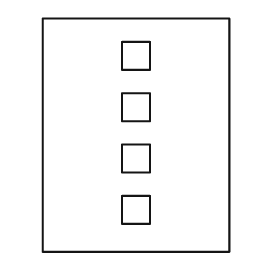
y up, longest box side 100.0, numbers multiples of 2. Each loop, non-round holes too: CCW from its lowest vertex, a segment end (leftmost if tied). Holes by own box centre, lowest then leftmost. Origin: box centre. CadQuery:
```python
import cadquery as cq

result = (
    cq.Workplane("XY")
    .moveTo(-40.0, -50.0)
    .lineTo(40.0, -50.0)
    .lineTo(40.0, 50.0)
    .lineTo(-40.0, 50.0)
    .close()
    .moveTo(-6.0, -38.0)
    .lineTo(6.0, -38.0)
    .lineTo(6.0, -26.0)
    .lineTo(-6.0, -26.0)
    .close()
    .moveTo(-6.0, -16.0)
    .lineTo(6.0, -16.0)
    .lineTo(6.0, -4.0)
    .lineTo(-6.0, -4.0)
    .close()
    .moveTo(-6.0, 6.0)
    .lineTo(6.0, 6.0)
    .lineTo(6.0, 18.0)
    .lineTo(-6.0, 18.0)
    .close()
    .moveTo(-6.0, 28.0)
    .lineTo(6.0, 28.0)
    .lineTo(6.0, 40.0)
    .lineTo(-6.0, 40.0)
    .close()
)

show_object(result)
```